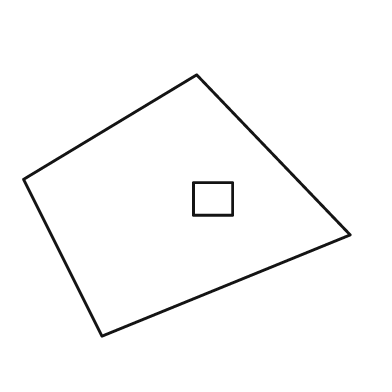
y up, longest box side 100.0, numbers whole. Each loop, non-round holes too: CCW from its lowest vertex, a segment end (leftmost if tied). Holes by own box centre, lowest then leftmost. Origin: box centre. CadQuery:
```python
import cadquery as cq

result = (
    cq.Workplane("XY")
    .moveTo(-26.0, -40.0)
    .lineTo(50.0, -9.0)
    .lineTo(3.0, 40.0)
    .lineTo(-50.0, 8.0)
    .close()
    .moveTo(2.0, -3.0)
    .lineTo(14.0, -3.0)
    .lineTo(14.0, 7.0)
    .lineTo(2.0, 7.0)
    .close()
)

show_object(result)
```